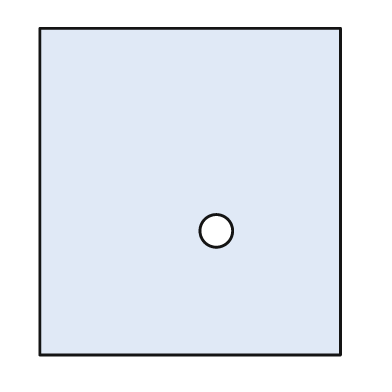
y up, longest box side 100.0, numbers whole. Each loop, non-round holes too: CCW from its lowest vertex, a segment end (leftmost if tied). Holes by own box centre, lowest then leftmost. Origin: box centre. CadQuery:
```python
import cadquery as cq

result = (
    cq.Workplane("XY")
    .moveTo(-46.0, -50.0)
    .lineTo(46.0, -50.0)
    .lineTo(46.0, 50.0)
    .lineTo(-46.0, 50.0)
    .close()
    .moveTo(8.0, -12.0)
    .circle(5.0)
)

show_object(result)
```